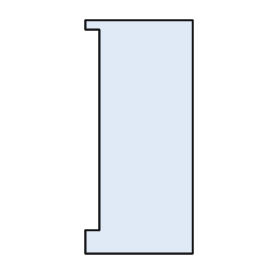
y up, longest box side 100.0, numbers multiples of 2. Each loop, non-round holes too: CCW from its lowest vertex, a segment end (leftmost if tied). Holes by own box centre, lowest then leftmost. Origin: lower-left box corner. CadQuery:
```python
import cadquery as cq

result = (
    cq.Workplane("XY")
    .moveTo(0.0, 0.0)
    .lineTo(46.0, 0.0)
    .lineTo(46.0, 100.0)
    .lineTo(0.0, 100.0)
    .lineTo(0.0, 96.0)
    .lineTo(6.0, 96.0)
    .lineTo(6.0, 10.0)
    .lineTo(0.0, 10.0)
    .close()
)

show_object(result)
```